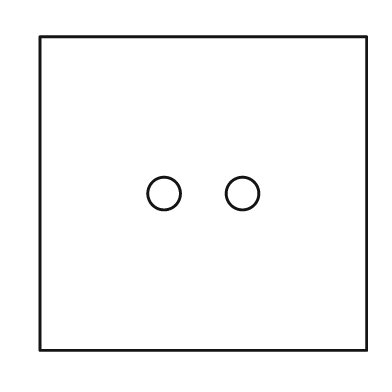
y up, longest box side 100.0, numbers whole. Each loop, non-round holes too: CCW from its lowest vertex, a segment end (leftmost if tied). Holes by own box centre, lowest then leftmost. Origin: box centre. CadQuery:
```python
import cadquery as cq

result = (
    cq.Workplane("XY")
    .moveTo(-50.0, -48.0)
    .lineTo(50.0, -48.0)
    .lineTo(50.0, 48.0)
    .lineTo(-50.0, 48.0)
    .close()
    .moveTo(-12.0, 0.0)
    .circle(5.0)
    .moveTo(12.0, 0.0)
    .circle(5.0)
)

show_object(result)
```